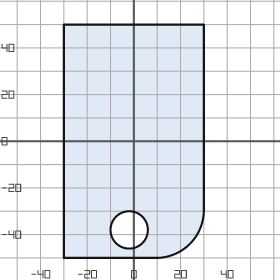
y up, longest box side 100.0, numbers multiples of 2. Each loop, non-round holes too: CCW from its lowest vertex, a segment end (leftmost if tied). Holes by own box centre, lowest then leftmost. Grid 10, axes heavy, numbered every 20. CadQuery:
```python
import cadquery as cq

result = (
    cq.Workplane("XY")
    .moveTo(-30.0, -50.0)
    .lineTo(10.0, -50.0)
    .threePointArc((24.0, -44.0), (30.0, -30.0))
    .lineTo(30.0, 50.0)
    .lineTo(-30.0, 50.0)
    .close()
    .moveTo(-2.0, -38.0)
    .circle(8.0)
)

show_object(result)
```